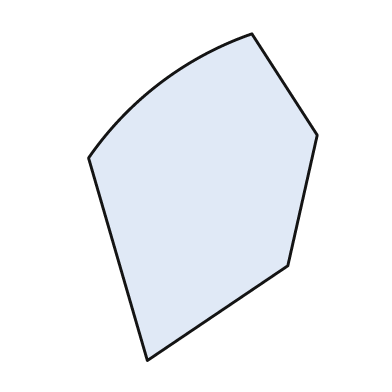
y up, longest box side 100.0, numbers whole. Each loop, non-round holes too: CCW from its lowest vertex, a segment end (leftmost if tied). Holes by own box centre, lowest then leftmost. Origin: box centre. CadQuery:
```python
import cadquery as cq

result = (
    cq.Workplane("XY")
    .moveTo(-17.0, -50.0)
    .lineTo(26.0, -21.0)
    .lineTo(35.0, 19.0)
    .lineTo(15.0, 50.0)
    .threePointArc((-13.0, 35.0), (-35.0, 12.0))
    .close()
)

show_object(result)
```